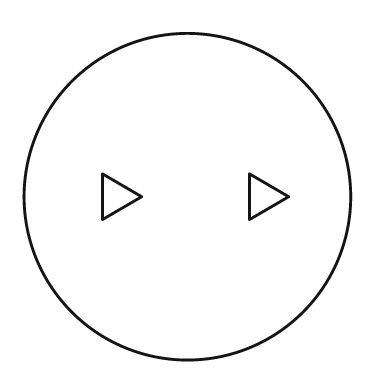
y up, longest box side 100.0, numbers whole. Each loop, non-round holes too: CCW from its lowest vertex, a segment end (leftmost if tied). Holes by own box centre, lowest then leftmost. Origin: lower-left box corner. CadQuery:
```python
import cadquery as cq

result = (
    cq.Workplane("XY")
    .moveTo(50.0, 50.0)
    .circle(50.0)
    .moveTo(24.0, 43.0)
    .lineTo(36.0, 50.0)
    .lineTo(24.0, 57.0)
    .close()
    .moveTo(69.0, 43.0)
    .lineTo(81.0, 50.0)
    .lineTo(69.0, 57.0)
    .close()
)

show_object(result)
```